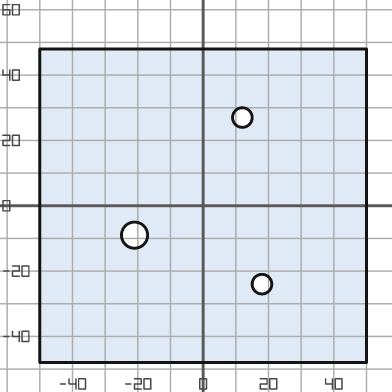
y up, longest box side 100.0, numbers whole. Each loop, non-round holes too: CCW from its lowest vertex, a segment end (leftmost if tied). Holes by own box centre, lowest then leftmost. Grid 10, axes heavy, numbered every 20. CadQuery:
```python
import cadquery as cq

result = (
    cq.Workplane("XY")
    .moveTo(-50.0, -48.0)
    .lineTo(50.0, -48.0)
    .lineTo(50.0, 48.0)
    .lineTo(-50.0, 48.0)
    .close()
    .moveTo(18.0, -24.0)
    .circle(3.0)
    .moveTo(-21.0, -9.0)
    .circle(4.0)
    .moveTo(12.0, 27.0)
    .circle(3.0)
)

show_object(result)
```